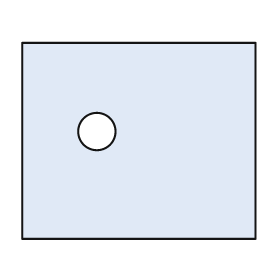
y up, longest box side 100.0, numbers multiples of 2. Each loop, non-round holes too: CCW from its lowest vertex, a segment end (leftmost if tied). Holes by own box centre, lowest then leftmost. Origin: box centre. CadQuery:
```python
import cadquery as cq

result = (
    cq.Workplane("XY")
    .moveTo(-50.0, -42.0)
    .lineTo(50.0, -42.0)
    .lineTo(50.0, 42.0)
    .lineTo(-50.0, 42.0)
    .close()
    .moveTo(-18.0, 4.0)
    .circle(8.0)
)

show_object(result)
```